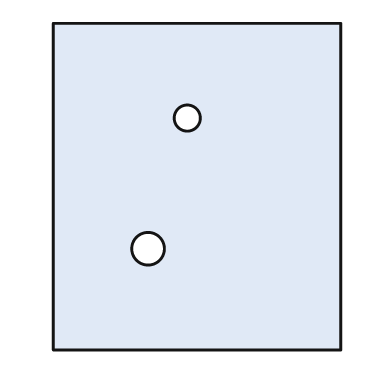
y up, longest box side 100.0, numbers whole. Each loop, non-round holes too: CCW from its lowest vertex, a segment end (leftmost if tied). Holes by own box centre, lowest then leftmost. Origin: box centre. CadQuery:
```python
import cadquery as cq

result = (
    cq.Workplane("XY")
    .moveTo(-44.0, -50.0)
    .lineTo(44.0, -50.0)
    .lineTo(44.0, 50.0)
    .lineTo(-44.0, 50.0)
    .close()
    .moveTo(-15.0, -19.0)
    .circle(5.0)
    .moveTo(-3.0, 21.0)
    .circle(4.0)
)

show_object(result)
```